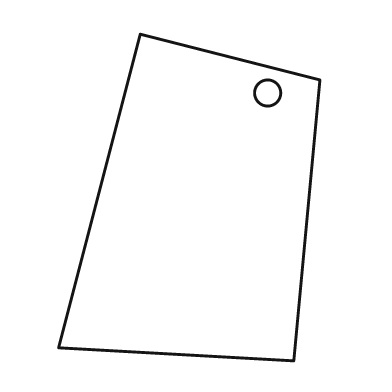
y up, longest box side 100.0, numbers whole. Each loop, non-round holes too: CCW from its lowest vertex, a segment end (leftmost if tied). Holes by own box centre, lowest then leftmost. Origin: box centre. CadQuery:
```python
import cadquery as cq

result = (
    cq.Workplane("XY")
    .moveTo(32.0, -50.0)
    .lineTo(40.0, 36.0)
    .lineTo(-15.0, 50.0)
    .lineTo(-40.0, -46.0)
    .close()
    .moveTo(24.0, 32.0)
    .circle(4.0)
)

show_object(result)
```